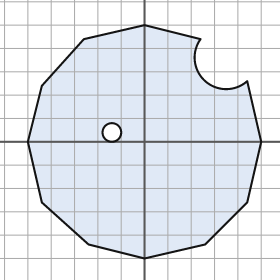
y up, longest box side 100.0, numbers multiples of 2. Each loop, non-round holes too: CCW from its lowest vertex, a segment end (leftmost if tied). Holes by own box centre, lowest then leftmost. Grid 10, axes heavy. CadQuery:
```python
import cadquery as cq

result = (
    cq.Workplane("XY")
    .moveTo(0.0, -50.0)
    .lineTo(26.0, -44.0)
    .lineTo(44.0, -26.0)
    .lineTo(50.0, 0.0)
    .lineTo(44.0, 26.0)
    .threePointArc((26.0, 26.0), (24.0, 44.0))
    .lineTo(0.0, 50.0)
    .lineTo(-26.0, 44.0)
    .lineTo(-44.0, 24.0)
    .lineTo(-50.0, 0.0)
    .lineTo(-44.0, -26.0)
    .lineTo(-24.0, -44.0)
    .close()
    .moveTo(-14.0, 4.0)
    .circle(4.0)
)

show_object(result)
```